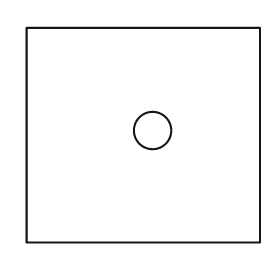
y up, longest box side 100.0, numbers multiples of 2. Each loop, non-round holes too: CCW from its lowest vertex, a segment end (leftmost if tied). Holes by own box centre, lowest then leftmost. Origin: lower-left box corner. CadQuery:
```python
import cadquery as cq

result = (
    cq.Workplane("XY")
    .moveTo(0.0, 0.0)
    .lineTo(100.0, 0.0)
    .lineTo(100.0, 92.0)
    .lineTo(0.0, 92.0)
    .close()
    .moveTo(54.0, 48.0)
    .circle(8.0)
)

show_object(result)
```